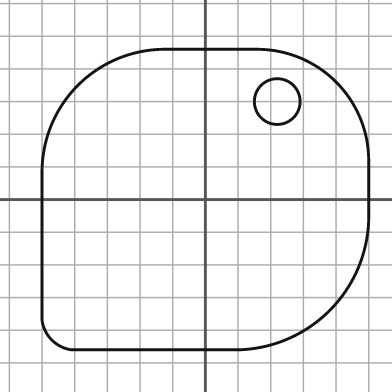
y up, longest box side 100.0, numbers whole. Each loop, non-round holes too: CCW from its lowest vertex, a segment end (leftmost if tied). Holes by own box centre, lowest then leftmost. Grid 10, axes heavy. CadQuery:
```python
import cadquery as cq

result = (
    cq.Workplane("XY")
    .moveTo(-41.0, -46.0)
    .lineTo(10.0, -46.0)
    .threePointArc((38.0, -34.0), (50.0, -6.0))
    .lineTo(50.0, 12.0)
    .threePointArc((40.0, 36.0), (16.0, 46.0))
    .lineTo(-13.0, 46.0)
    .threePointArc((-39.0, 35.0), (-50.0, 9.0))
    .lineTo(-50.0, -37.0)
    .threePointArc((-47.0, -43.0), (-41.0, -46.0))
    .close()
    .moveTo(22.0, 30.0)
    .circle(7.0)
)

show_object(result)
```